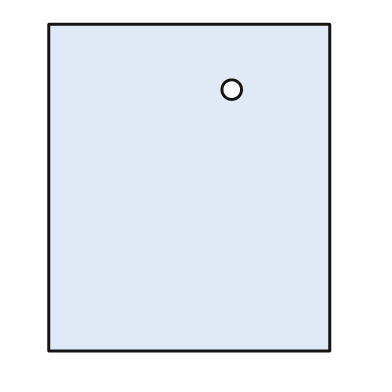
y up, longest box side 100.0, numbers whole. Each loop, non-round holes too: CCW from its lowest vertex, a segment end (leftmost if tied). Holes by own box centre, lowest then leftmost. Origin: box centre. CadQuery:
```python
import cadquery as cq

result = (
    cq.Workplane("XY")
    .moveTo(-43.0, -50.0)
    .lineTo(43.0, -50.0)
    .lineTo(43.0, 50.0)
    .lineTo(-43.0, 50.0)
    .close()
    .moveTo(13.0, 30.0)
    .circle(3.0)
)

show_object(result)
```